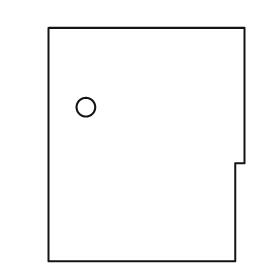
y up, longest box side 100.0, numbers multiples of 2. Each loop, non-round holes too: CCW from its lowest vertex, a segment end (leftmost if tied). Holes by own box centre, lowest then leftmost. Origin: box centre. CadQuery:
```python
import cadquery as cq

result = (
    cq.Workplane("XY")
    .moveTo(-42.0, -50.0)
    .lineTo(38.0, -50.0)
    .lineTo(38.0, -8.0)
    .lineTo(42.0, -8.0)
    .lineTo(42.0, 50.0)
    .lineTo(-42.0, 50.0)
    .close()
    .moveTo(-26.0, 16.0)
    .circle(4.0)
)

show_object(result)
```